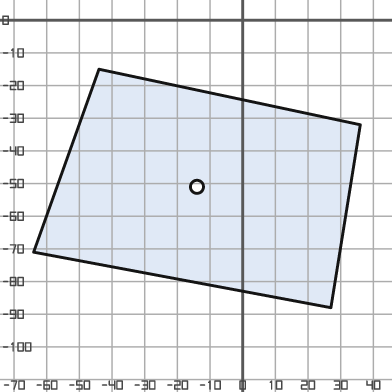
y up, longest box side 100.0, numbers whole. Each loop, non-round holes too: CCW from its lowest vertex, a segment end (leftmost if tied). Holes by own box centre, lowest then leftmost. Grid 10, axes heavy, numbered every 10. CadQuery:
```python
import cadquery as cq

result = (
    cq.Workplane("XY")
    .moveTo(27.0, -88.0)
    .lineTo(36.0, -32.0)
    .lineTo(-44.0, -15.0)
    .lineTo(-64.0, -71.0)
    .close()
    .moveTo(-14.0, -51.0)
    .circle(2.0)
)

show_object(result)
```